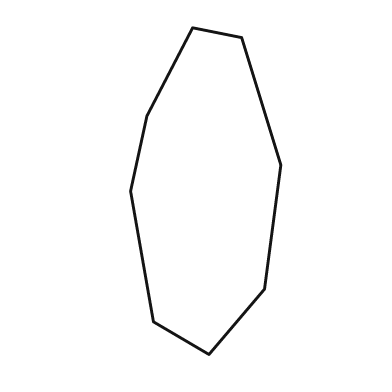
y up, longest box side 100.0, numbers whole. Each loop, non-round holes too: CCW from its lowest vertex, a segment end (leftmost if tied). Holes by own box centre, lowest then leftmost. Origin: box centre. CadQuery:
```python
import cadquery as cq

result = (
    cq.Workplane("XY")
    .moveTo(1.0, -50.0)
    .lineTo(18.0, -30.0)
    .lineTo(23.0, 8.0)
    .lineTo(11.0, 47.0)
    .lineTo(-4.0, 50.0)
    .lineTo(-18.0, 23.0)
    .lineTo(-23.0, 0.0)
    .lineTo(-16.0, -40.0)
    .close()
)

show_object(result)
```